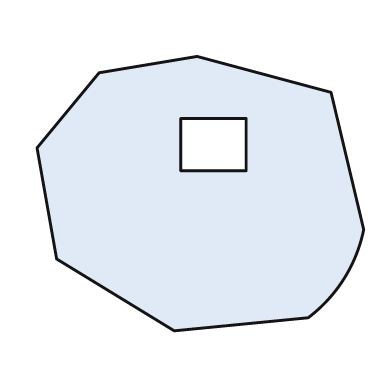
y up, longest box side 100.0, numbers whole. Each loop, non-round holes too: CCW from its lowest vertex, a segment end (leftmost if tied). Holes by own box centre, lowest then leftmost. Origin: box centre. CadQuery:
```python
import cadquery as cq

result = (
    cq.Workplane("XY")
    .moveTo(-8.0, -42.0)
    .lineTo(33.0, -38.0)
    .threePointArc((44.0, -26.0), (50.0, -11.0))
    .lineTo(40.0, 31.0)
    .lineTo(-1.0, 42.0)
    .lineTo(-31.0, 37.0)
    .lineTo(-50.0, 14.0)
    .lineTo(-44.0, -20.0)
    .close()
    .moveTo(-6.0, 7.0)
    .lineTo(14.0, 7.0)
    .lineTo(14.0, 23.0)
    .lineTo(-6.0, 23.0)
    .close()
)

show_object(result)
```